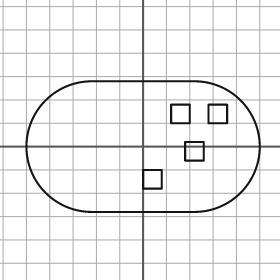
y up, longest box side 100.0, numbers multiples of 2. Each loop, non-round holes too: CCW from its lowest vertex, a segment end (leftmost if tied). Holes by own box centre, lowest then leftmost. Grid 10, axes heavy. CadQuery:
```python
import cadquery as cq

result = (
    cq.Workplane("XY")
    .moveTo(-22.0, -28.0)
    .lineTo(22.0, -28.0)
    .threePointArc((50.0, 0.0), (22.0, 28.0))
    .lineTo(-22.0, 28.0)
    .threePointArc((-50.0, 0.0), (-22.0, -28.0))
    .close()
    .moveTo(0.0, -18.0)
    .lineTo(8.0, -18.0)
    .lineTo(8.0, -10.0)
    .lineTo(0.0, -10.0)
    .close()
    .moveTo(18.0, -6.0)
    .lineTo(26.0, -6.0)
    .lineTo(26.0, 2.0)
    .lineTo(18.0, 2.0)
    .close()
    .moveTo(12.0, 10.0)
    .lineTo(20.0, 10.0)
    .lineTo(20.0, 18.0)
    .lineTo(12.0, 18.0)
    .close()
    .moveTo(28.0, 10.0)
    .lineTo(36.0, 10.0)
    .lineTo(36.0, 18.0)
    .lineTo(28.0, 18.0)
    .close()
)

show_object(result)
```